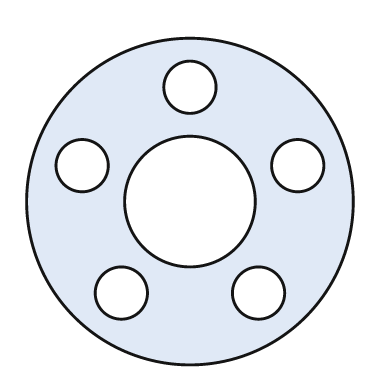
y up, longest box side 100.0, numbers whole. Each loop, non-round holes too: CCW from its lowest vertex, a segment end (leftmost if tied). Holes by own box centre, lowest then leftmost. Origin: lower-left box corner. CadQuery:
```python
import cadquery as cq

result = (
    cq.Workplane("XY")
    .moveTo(50.0, 50.0)
    .circle(50.0)
    .moveTo(29.0, 22.0)
    .circle(8.0)
    .moveTo(71.0, 22.0)
    .circle(8.0)
    .moveTo(50.0, 50.0)
    .circle(20.0)
    .moveTo(17.0, 61.0)
    .circle(8.0)
    .moveTo(83.0, 61.0)
    .circle(8.0)
    .moveTo(50.0, 85.0)
    .circle(8.0)
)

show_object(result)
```